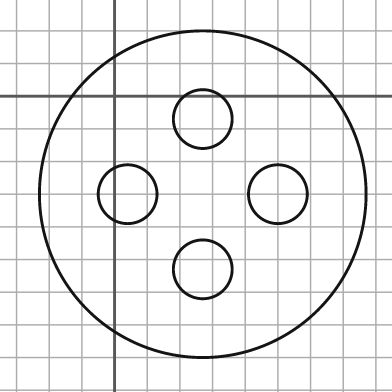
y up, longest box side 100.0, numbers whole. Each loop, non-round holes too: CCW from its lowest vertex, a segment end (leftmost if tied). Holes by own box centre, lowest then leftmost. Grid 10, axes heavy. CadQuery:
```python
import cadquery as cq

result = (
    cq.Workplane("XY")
    .moveTo(27.0, -30.0)
    .circle(50.0)
    .moveTo(27.0, -53.0)
    .circle(9.0)
    .moveTo(4.0, -30.0)
    .circle(9.0)
    .moveTo(50.0, -30.0)
    .circle(9.0)
    .moveTo(27.0, -7.0)
    .circle(9.0)
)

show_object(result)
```